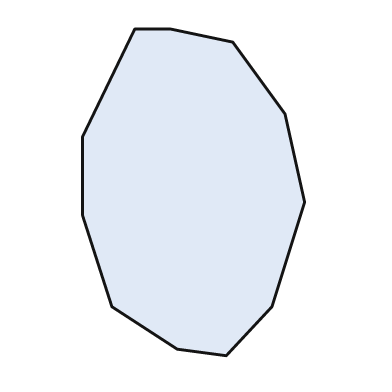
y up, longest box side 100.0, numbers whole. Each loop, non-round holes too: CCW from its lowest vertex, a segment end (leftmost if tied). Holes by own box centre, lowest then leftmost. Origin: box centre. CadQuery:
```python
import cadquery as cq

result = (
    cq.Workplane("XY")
    .moveTo(10.0, -50.0)
    .lineTo(24.0, -35.0)
    .lineTo(34.0, -3.0)
    .lineTo(28.0, 24.0)
    .lineTo(12.0, 46.0)
    .lineTo(-7.0, 50.0)
    .lineTo(-18.0, 50.0)
    .lineTo(-34.0, 17.0)
    .lineTo(-34.0, -7.0)
    .lineTo(-25.0, -35.0)
    .lineTo(-5.0, -48.0)
    .close()
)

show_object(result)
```